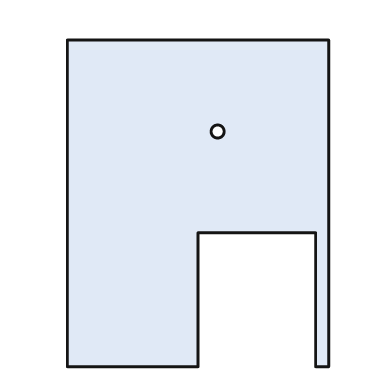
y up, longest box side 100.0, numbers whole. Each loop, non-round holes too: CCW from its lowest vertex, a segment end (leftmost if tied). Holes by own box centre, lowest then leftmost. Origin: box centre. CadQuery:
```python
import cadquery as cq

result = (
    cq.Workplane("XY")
    .moveTo(-40.0, -50.0)
    .lineTo(0.0, -50.0)
    .lineTo(0.0, -9.0)
    .lineTo(36.0, -9.0)
    .lineTo(36.0, -50.0)
    .lineTo(40.0, -50.0)
    .lineTo(40.0, 50.0)
    .lineTo(-40.0, 50.0)
    .close()
    .moveTo(6.0, 22.0)
    .circle(2.0)
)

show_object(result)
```